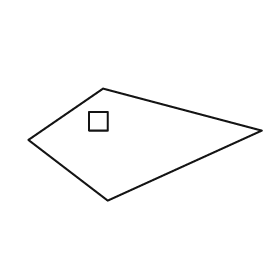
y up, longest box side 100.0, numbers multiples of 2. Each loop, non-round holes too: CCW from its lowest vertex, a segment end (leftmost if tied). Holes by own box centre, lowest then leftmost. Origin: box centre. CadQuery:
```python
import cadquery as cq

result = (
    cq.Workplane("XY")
    .moveTo(-16.0, -24.0)
    .lineTo(50.0, 6.0)
    .lineTo(-18.0, 24.0)
    .lineTo(-50.0, 2.0)
    .close()
    .moveTo(-24.0, 6.0)
    .lineTo(-16.0, 6.0)
    .lineTo(-16.0, 14.0)
    .lineTo(-24.0, 14.0)
    .close()
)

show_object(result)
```